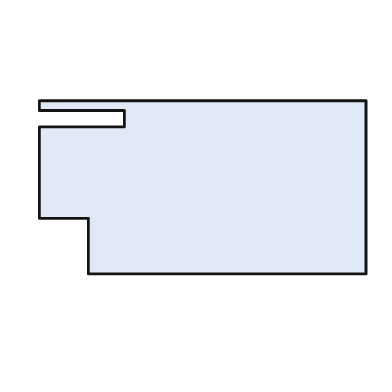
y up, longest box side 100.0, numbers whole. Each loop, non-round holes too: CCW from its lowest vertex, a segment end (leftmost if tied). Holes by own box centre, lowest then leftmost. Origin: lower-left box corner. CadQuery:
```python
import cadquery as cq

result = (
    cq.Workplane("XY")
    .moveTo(15.0, 0.0)
    .lineTo(100.0, 0.0)
    .lineTo(100.0, 53.0)
    .lineTo(0.0, 53.0)
    .lineTo(0.0, 50.0)
    .lineTo(26.0, 50.0)
    .lineTo(26.0, 45.0)
    .lineTo(0.0, 45.0)
    .lineTo(0.0, 17.0)
    .lineTo(15.0, 17.0)
    .close()
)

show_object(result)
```